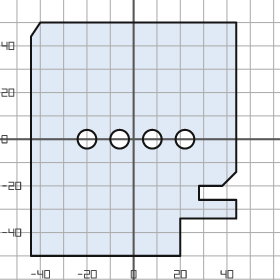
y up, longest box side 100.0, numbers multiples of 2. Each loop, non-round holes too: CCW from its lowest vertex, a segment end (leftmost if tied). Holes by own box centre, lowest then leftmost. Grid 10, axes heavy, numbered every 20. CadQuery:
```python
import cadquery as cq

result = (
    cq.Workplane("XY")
    .moveTo(-44.0, -50.0)
    .lineTo(20.0, -50.0)
    .lineTo(20.0, -34.0)
    .lineTo(44.0, -34.0)
    .lineTo(44.0, -26.0)
    .lineTo(28.0, -26.0)
    .lineTo(28.0, -20.0)
    .lineTo(38.0, -20.0)
    .lineTo(44.0, -14.0)
    .lineTo(44.0, 50.0)
    .lineTo(-40.0, 50.0)
    .lineTo(-44.0, 44.0)
    .close()
    .moveTo(-20.0, 0.0)
    .circle(4.0)
    .moveTo(-6.0, 0.0)
    .circle(4.0)
    .moveTo(8.0, 0.0)
    .circle(4.0)
    .moveTo(22.0, 0.0)
    .circle(4.0)
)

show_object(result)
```